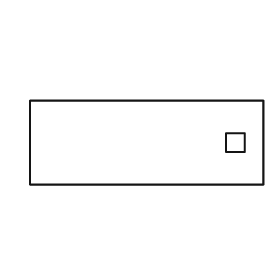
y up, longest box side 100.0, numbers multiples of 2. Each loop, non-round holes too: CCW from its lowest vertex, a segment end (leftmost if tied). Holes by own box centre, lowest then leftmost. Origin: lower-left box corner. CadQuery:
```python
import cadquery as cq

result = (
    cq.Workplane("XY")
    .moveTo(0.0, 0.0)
    .lineTo(100.0, 0.0)
    .lineTo(100.0, 36.0)
    .lineTo(0.0, 36.0)
    .close()
    .moveTo(84.0, 14.0)
    .lineTo(92.0, 14.0)
    .lineTo(92.0, 22.0)
    .lineTo(84.0, 22.0)
    .close()
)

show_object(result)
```